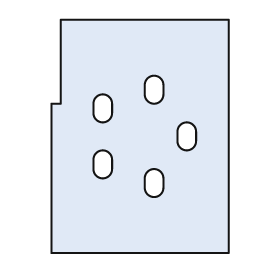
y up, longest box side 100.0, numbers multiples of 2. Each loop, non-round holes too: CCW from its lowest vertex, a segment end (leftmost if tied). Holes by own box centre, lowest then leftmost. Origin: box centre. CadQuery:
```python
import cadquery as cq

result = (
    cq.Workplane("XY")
    .moveTo(-38.0, -50.0)
    .lineTo(38.0, -50.0)
    .lineTo(38.0, 50.0)
    .lineTo(-34.0, 50.0)
    .lineTo(-34.0, 14.0)
    .lineTo(-38.0, 14.0)
    .close()
    .moveTo(2.0, -22.0)
    .threePointArc((6.0, -26.0), (10.0, -22.0))
    .lineTo(10.0, -18.0)
    .threePointArc((6.0, -14.0), (2.0, -18.0))
    .close()
    .moveTo(-20.0, -14.0)
    .threePointArc((-16.0, -18.0), (-12.0, -14.0))
    .lineTo(-12.0, -10.0)
    .threePointArc((-16.0, -6.0), (-20.0, -10.0))
    .close()
    .moveTo(16.0, -2.0)
    .threePointArc((20.0, -6.0), (24.0, -2.0))
    .lineTo(24.0, 2.0)
    .threePointArc((20.0, 6.0), (16.0, 2.0))
    .close()
    .moveTo(-20.0, 10.0)
    .threePointArc((-16.0, 6.0), (-12.0, 10.0))
    .lineTo(-12.0, 14.0)
    .threePointArc((-16.0, 18.0), (-20.0, 14.0))
    .close()
    .moveTo(2.0, 18.0)
    .threePointArc((6.0, 14.0), (10.0, 18.0))
    .lineTo(10.0, 22.0)
    .threePointArc((6.0, 26.0), (2.0, 22.0))
    .close()
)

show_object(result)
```